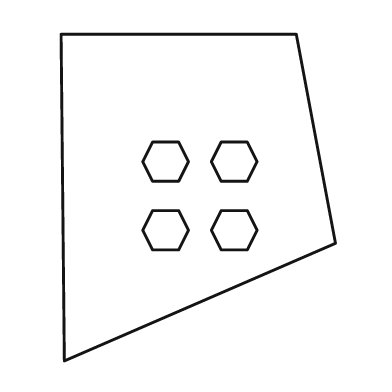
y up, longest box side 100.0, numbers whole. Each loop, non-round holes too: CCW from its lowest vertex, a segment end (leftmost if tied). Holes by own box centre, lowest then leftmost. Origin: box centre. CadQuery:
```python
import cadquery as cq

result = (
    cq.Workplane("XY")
    .moveTo(-41.0, -50.0)
    .lineTo(42.0, -14.0)
    .lineTo(30.0, 50.0)
    .lineTo(-42.0, 50.0)
    .close()
    .moveTo(-14.0, -16.0)
    .lineTo(-6.0, -16.0)
    .lineTo(-3.0, -10.0)
    .lineTo(-6.0, -4.0)
    .lineTo(-14.0, -4.0)
    .lineTo(-17.0, -10.0)
    .close()
    .moveTo(7.0, -16.0)
    .lineTo(15.0, -16.0)
    .lineTo(18.0, -10.0)
    .lineTo(15.0, -4.0)
    .lineTo(7.0, -4.0)
    .lineTo(4.0, -10.0)
    .close()
    .moveTo(-14.0, 5.0)
    .lineTo(-6.0, 5.0)
    .lineTo(-3.0, 11.0)
    .lineTo(-6.0, 17.0)
    .lineTo(-14.0, 17.0)
    .lineTo(-17.0, 11.0)
    .close()
    .moveTo(7.0, 5.0)
    .lineTo(15.0, 5.0)
    .lineTo(18.0, 11.0)
    .lineTo(15.0, 17.0)
    .lineTo(7.0, 17.0)
    .lineTo(4.0, 11.0)
    .close()
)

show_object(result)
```